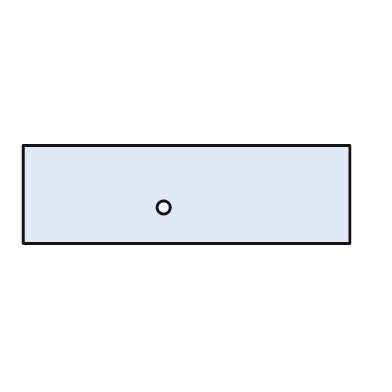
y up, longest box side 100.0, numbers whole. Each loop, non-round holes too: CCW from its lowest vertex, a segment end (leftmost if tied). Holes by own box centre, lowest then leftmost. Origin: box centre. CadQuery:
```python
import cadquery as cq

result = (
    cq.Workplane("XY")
    .moveTo(-50.0, -15.0)
    .lineTo(50.0, -15.0)
    .lineTo(50.0, 15.0)
    .lineTo(-50.0, 15.0)
    .close()
    .moveTo(-7.0, -4.0)
    .circle(2.0)
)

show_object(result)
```